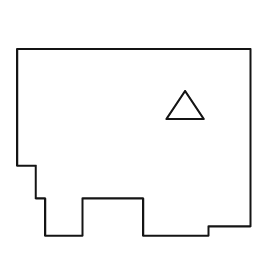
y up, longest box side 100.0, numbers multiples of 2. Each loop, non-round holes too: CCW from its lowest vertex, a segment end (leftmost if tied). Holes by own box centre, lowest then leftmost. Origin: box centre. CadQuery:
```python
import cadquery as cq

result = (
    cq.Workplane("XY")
    .moveTo(-38.0, -40.0)
    .lineTo(-22.0, -40.0)
    .lineTo(-22.0, -24.0)
    .lineTo(4.0, -24.0)
    .lineTo(4.0, -40.0)
    .lineTo(32.0, -40.0)
    .lineTo(32.0, -36.0)
    .lineTo(50.0, -36.0)
    .lineTo(50.0, 40.0)
    .lineTo(-50.0, 40.0)
    .lineTo(-50.0, -10.0)
    .lineTo(-42.0, -10.0)
    .lineTo(-42.0, -24.0)
    .lineTo(-38.0, -24.0)
    .close()
    .moveTo(14.0, 10.0)
    .lineTo(30.0, 10.0)
    .lineTo(22.0, 22.0)
    .close()
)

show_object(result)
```